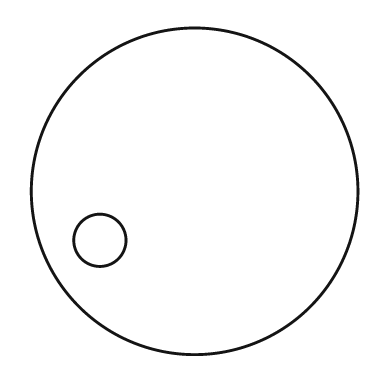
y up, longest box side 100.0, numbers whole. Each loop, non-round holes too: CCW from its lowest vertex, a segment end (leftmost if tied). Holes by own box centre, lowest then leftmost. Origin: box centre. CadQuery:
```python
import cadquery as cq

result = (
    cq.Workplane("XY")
    .moveTo(0.0, 0.0)
    .circle(50.0)
    .moveTo(-29.0, -15.0)
    .circle(8.0)
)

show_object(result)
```